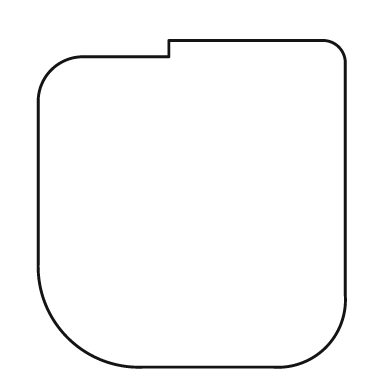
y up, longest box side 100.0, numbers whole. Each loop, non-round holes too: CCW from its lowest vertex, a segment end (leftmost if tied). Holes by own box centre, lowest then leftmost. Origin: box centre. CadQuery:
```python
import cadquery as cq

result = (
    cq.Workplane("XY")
    .moveTo(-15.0, -50.0)
    .lineTo(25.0, -50.0)
    .threePointArc((41.0, -44.0), (47.0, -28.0))
    .lineTo(47.0, 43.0)
    .threePointArc((45.0, 48.0), (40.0, 50.0))
    .lineTo(-7.0, 50.0)
    .lineTo(-7.0, 45.0)
    .lineTo(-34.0, 45.0)
    .threePointArc((-43.0, 41.0), (-47.0, 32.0))
    .lineTo(-47.0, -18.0)
    .threePointArc((-38.0, -41.0), (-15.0, -50.0))
    .close()
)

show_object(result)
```